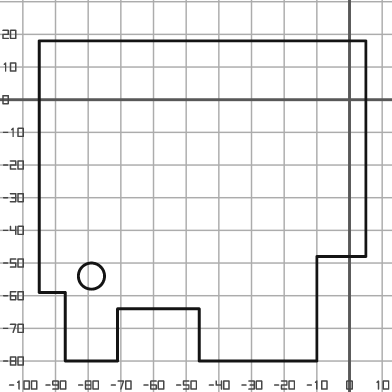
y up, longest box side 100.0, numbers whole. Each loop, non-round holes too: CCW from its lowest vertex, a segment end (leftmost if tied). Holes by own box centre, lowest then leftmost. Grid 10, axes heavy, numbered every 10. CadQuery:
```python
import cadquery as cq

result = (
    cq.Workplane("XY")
    .moveTo(-87.0, -80.0)
    .lineTo(-71.0, -80.0)
    .lineTo(-71.0, -64.0)
    .lineTo(-46.0, -64.0)
    .lineTo(-46.0, -80.0)
    .lineTo(-10.0, -80.0)
    .lineTo(-10.0, -48.0)
    .lineTo(5.0, -48.0)
    .lineTo(5.0, 18.0)
    .lineTo(-95.0, 18.0)
    .lineTo(-95.0, -59.0)
    .lineTo(-87.0, -59.0)
    .close()
    .moveTo(-79.0, -54.0)
    .circle(4.0)
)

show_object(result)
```